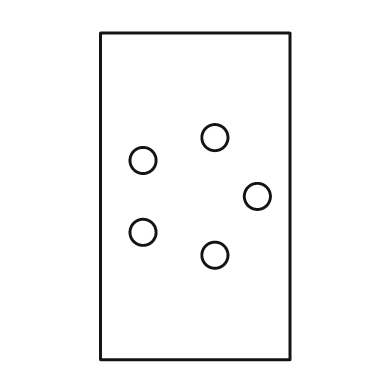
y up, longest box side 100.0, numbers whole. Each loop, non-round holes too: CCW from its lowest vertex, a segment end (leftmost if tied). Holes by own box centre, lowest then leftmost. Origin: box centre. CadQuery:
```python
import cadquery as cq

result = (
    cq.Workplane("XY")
    .moveTo(-29.0, -50.0)
    .lineTo(29.0, -50.0)
    .lineTo(29.0, 50.0)
    .lineTo(-29.0, 50.0)
    .close()
    .moveTo(6.0, -18.0)
    .circle(4.0)
    .moveTo(-16.0, -11.0)
    .circle(4.0)
    .moveTo(19.0, 0.0)
    .circle(4.0)
    .moveTo(-16.0, 11.0)
    .circle(4.0)
    .moveTo(6.0, 18.0)
    .circle(4.0)
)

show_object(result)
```